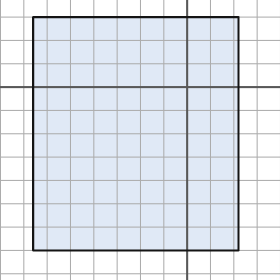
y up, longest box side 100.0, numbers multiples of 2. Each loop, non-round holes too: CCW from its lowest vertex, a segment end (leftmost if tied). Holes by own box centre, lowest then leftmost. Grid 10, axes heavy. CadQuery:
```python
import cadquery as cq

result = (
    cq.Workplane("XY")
    .moveTo(-66.0, -70.0)
    .lineTo(22.0, -70.0)
    .lineTo(22.0, 30.0)
    .lineTo(-66.0, 30.0)
    .close()
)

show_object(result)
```